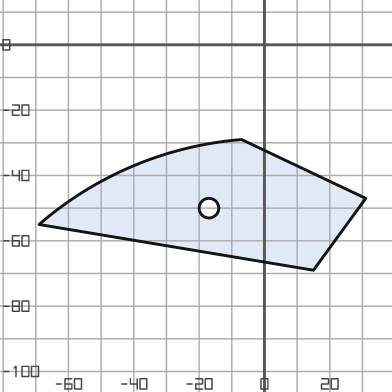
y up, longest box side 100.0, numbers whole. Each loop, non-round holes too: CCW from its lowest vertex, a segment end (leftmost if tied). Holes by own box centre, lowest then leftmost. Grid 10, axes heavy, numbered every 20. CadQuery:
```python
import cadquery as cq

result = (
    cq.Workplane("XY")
    .moveTo(15.0, -69.0)
    .lineTo(31.0, -47.0)
    .lineTo(-7.0, -29.0)
    .threePointArc((-40.0, -37.0), (-69.0, -55.0))
    .close()
    .moveTo(-17.0, -50.0)
    .circle(3.0)
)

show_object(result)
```